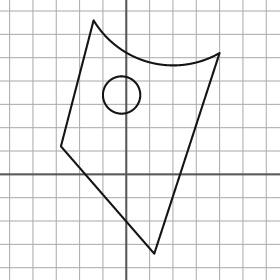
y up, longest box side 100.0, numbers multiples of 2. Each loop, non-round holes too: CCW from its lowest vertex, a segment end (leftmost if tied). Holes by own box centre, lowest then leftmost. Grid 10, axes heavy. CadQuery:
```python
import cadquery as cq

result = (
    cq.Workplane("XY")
    .moveTo(12.0, -34.0)
    .lineTo(40.0, 52.0)
    .threePointArc((10.0, 48.0), (-14.0, 66.0))
    .lineTo(-28.0, 12.0)
    .close()
    .moveTo(-2.0, 34.0)
    .circle(8.0)
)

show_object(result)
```